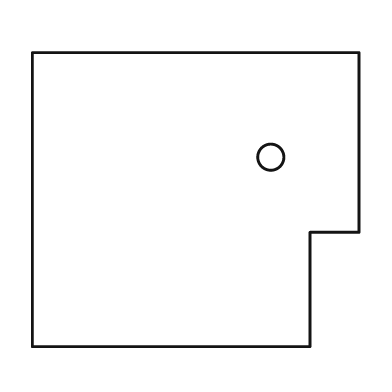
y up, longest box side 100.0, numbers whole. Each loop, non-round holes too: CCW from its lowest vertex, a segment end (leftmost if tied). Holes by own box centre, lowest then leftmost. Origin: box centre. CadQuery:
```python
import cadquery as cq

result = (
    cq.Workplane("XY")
    .moveTo(-50.0, -45.0)
    .lineTo(35.0, -45.0)
    .lineTo(35.0, -10.0)
    .lineTo(50.0, -10.0)
    .lineTo(50.0, 45.0)
    .lineTo(-50.0, 45.0)
    .close()
    .moveTo(23.0, 13.0)
    .circle(4.0)
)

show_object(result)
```